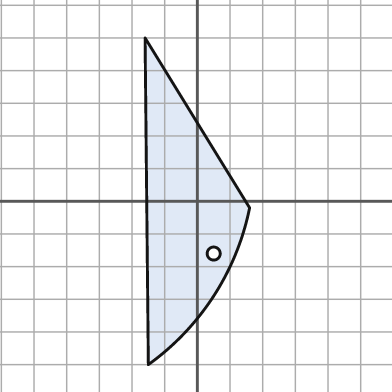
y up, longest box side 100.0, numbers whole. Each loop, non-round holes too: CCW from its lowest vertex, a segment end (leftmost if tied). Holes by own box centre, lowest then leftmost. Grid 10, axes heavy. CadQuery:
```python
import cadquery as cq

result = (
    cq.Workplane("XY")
    .moveTo(-15.0, -50.0)
    .threePointArc((5.0, -29.0), (16.0, -2.0))
    .lineTo(-16.0, 50.0)
    .close()
    .moveTo(5.0, -16.0)
    .circle(2.0)
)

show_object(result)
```